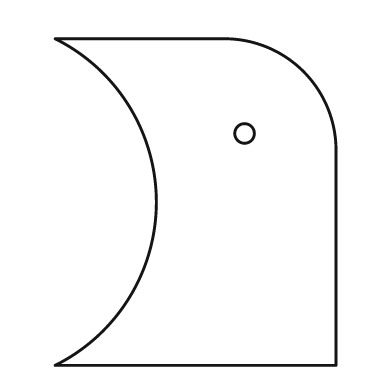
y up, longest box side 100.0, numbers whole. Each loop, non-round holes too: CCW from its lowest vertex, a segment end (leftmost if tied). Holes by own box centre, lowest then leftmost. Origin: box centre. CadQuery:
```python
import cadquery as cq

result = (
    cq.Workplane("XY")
    .moveTo(-43.0, -50.0)
    .lineTo(43.0, -50.0)
    .lineTo(43.0, 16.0)
    .threePointArc((33.0, 40.0), (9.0, 50.0))
    .lineTo(-43.0, 50.0)
    .threePointArc((-12.0, 0.0), (-43.0, -50.0))
    .close()
    .moveTo(15.0, 21.0)
    .circle(3.0)
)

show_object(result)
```